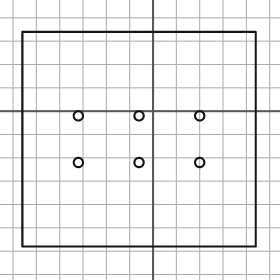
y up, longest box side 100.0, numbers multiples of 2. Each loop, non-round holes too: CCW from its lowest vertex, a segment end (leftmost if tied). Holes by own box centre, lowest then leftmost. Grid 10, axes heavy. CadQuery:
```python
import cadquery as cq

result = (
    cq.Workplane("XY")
    .moveTo(-56.0, -58.0)
    .lineTo(44.0, -58.0)
    .lineTo(44.0, 34.0)
    .lineTo(-56.0, 34.0)
    .close()
    .moveTo(-32.0, -22.0)
    .circle(2.0)
    .moveTo(-6.0, -22.0)
    .circle(2.0)
    .moveTo(20.0, -22.0)
    .circle(2.0)
    .moveTo(-32.0, -2.0)
    .circle(2.0)
    .moveTo(-6.0, -2.0)
    .circle(2.0)
    .moveTo(20.0, -2.0)
    .circle(2.0)
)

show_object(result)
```